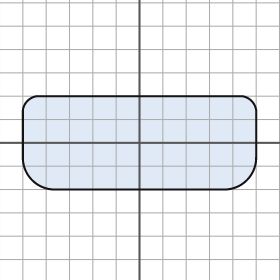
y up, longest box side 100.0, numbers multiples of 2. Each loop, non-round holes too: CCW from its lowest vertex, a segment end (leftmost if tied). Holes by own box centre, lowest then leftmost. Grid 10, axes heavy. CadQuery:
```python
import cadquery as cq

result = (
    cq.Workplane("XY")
    .moveTo(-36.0, -20.0)
    .lineTo(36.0, -20.0)
    .threePointArc((46.0, -16.0), (50.0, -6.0))
    .lineTo(50.0, 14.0)
    .threePointArc((48.0, 18.0), (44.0, 20.0))
    .lineTo(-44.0, 20.0)
    .threePointArc((-48.0, 18.0), (-50.0, 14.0))
    .lineTo(-50.0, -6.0)
    .threePointArc((-46.0, -16.0), (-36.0, -20.0))
    .close()
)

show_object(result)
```